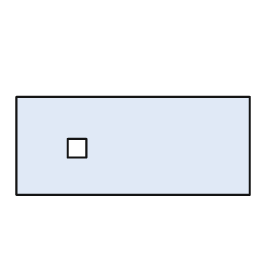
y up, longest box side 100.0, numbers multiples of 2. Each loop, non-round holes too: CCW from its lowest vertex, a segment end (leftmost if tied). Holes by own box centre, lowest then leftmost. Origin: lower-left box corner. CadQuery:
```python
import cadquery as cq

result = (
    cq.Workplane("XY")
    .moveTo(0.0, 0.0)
    .lineTo(100.0, 0.0)
    .lineTo(100.0, 42.0)
    .lineTo(0.0, 42.0)
    .close()
    .moveTo(22.0, 16.0)
    .lineTo(30.0, 16.0)
    .lineTo(30.0, 24.0)
    .lineTo(22.0, 24.0)
    .close()
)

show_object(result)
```